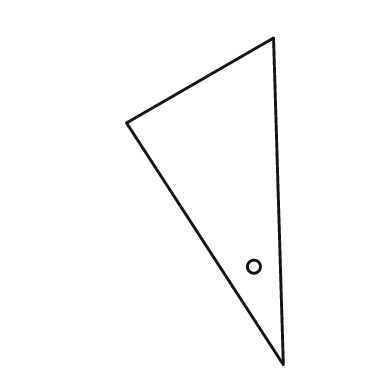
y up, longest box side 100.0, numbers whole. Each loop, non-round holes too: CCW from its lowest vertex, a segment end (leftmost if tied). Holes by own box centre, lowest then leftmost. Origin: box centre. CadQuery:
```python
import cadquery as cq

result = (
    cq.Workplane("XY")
    .moveTo(24.0, -50.0)
    .lineTo(21.0, 50.0)
    .lineTo(-24.0, 24.0)
    .close()
    .moveTo(15.0, -20.0)
    .circle(2.0)
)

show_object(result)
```